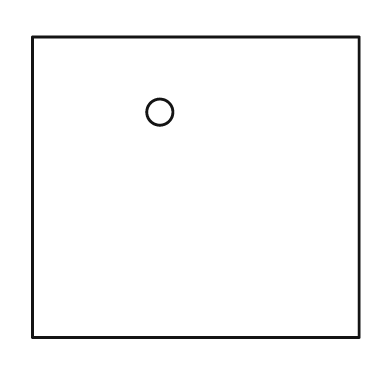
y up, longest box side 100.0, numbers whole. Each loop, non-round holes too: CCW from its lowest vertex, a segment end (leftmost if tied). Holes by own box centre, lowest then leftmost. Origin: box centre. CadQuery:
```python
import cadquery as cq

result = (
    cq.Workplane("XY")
    .moveTo(-50.0, -46.0)
    .lineTo(50.0, -46.0)
    .lineTo(50.0, 46.0)
    .lineTo(-50.0, 46.0)
    .close()
    .moveTo(-11.0, 23.0)
    .circle(4.0)
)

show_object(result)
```